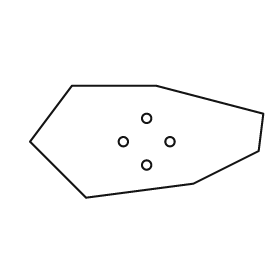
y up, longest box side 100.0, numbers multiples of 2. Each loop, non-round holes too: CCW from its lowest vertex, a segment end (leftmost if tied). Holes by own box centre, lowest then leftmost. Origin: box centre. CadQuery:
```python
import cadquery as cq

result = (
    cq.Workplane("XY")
    .moveTo(-26.0, -24.0)
    .lineTo(20.0, -18.0)
    .lineTo(48.0, -4.0)
    .lineTo(50.0, 12.0)
    .lineTo(4.0, 24.0)
    .lineTo(-32.0, 24.0)
    .lineTo(-50.0, 0.0)
    .close()
    .moveTo(0.0, -10.0)
    .circle(2.0)
    .moveTo(-10.0, 0.0)
    .circle(2.0)
    .moveTo(10.0, 0.0)
    .circle(2.0)
    .moveTo(0.0, 10.0)
    .circle(2.0)
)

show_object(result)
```